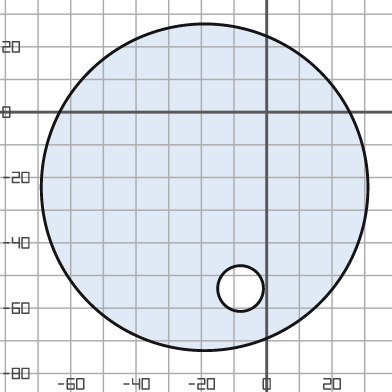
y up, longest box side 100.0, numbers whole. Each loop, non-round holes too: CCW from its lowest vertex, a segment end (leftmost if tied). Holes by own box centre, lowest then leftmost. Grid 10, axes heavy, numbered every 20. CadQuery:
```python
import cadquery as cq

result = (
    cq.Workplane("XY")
    .moveTo(-19.0, -23.0)
    .circle(50.0)
    .moveTo(-8.0, -54.0)
    .circle(7.0)
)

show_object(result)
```